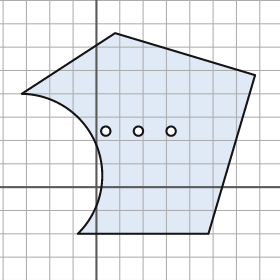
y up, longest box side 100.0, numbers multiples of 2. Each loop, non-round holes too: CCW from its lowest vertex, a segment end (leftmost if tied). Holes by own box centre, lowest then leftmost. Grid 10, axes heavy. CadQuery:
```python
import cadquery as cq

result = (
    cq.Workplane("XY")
    .moveTo(-8.0, -20.0)
    .lineTo(48.0, -20.0)
    .lineTo(68.0, 48.0)
    .lineTo(8.0, 66.0)
    .lineTo(-32.0, 40.0)
    .threePointArc((0.0, 18.0), (-8.0, -20.0))
    .close()
    .moveTo(4.0, 24.0)
    .circle(2.0)
    .moveTo(18.0, 24.0)
    .circle(2.0)
    .moveTo(32.0, 24.0)
    .circle(2.0)
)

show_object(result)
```